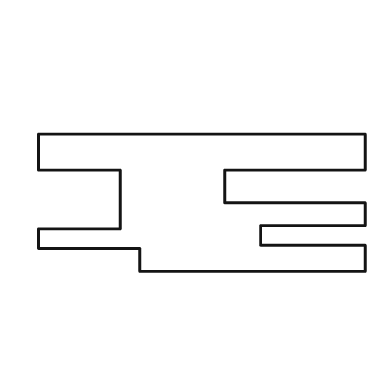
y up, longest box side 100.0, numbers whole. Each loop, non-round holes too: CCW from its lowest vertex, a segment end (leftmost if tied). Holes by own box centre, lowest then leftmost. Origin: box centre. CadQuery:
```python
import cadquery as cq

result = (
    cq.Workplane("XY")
    .moveTo(-19.0, -21.0)
    .lineTo(50.0, -21.0)
    .lineTo(50.0, -13.0)
    .lineTo(18.0, -13.0)
    .lineTo(18.0, -7.0)
    .lineTo(50.0, -7.0)
    .lineTo(50.0, 0.0)
    .lineTo(7.0, 0.0)
    .lineTo(7.0, 10.0)
    .lineTo(50.0, 10.0)
    .lineTo(50.0, 21.0)
    .lineTo(-50.0, 21.0)
    .lineTo(-50.0, 10.0)
    .lineTo(-25.0, 10.0)
    .lineTo(-25.0, -8.0)
    .lineTo(-50.0, -8.0)
    .lineTo(-50.0, -14.0)
    .lineTo(-19.0, -14.0)
    .close()
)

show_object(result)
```